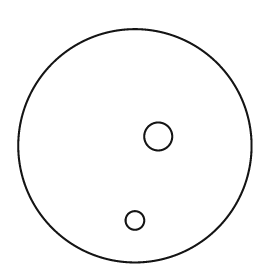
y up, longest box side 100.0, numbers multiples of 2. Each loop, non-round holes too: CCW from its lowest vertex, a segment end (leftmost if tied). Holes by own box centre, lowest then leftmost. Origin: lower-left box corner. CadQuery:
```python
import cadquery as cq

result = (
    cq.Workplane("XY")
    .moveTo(50.0, 50.0)
    .circle(50.0)
    .moveTo(50.0, 18.0)
    .circle(4.0)
    .moveTo(60.0, 54.0)
    .circle(6.0)
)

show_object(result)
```